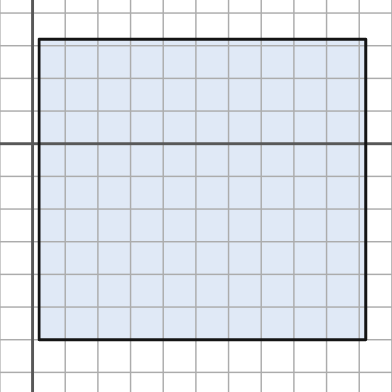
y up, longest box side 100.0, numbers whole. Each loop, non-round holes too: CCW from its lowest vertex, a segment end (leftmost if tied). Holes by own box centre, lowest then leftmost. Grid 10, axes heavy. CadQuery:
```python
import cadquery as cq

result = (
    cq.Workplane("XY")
    .moveTo(2.0, -60.0)
    .lineTo(102.0, -60.0)
    .lineTo(102.0, 32.0)
    .lineTo(2.0, 32.0)
    .close()
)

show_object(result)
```